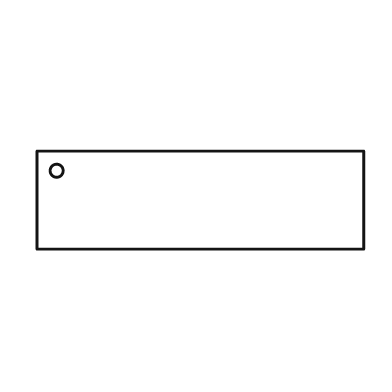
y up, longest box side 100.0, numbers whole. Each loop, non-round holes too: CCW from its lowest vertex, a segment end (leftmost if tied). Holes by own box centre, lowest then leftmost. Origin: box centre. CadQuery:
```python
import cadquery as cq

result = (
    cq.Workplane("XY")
    .moveTo(-50.0, -15.0)
    .lineTo(50.0, -15.0)
    .lineTo(50.0, 15.0)
    .lineTo(-50.0, 15.0)
    .close()
    .moveTo(-44.0, 9.0)
    .circle(2.0)
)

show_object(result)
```